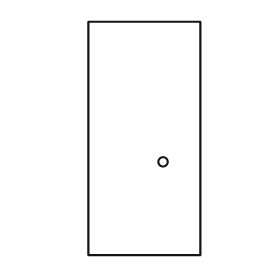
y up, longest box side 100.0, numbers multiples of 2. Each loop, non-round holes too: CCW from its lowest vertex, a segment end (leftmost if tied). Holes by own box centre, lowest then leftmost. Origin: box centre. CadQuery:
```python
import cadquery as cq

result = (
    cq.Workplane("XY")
    .moveTo(-24.0, -50.0)
    .lineTo(24.0, -50.0)
    .lineTo(24.0, 50.0)
    .lineTo(-24.0, 50.0)
    .close()
    .moveTo(8.0, -10.0)
    .circle(2.0)
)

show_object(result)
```